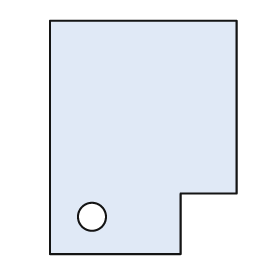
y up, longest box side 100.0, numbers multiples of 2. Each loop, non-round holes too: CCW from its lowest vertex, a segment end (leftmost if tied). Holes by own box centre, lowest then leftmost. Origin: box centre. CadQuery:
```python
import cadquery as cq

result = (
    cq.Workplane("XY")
    .moveTo(-40.0, -50.0)
    .lineTo(16.0, -50.0)
    .lineTo(16.0, -24.0)
    .lineTo(40.0, -24.0)
    .lineTo(40.0, 50.0)
    .lineTo(-40.0, 50.0)
    .close()
    .moveTo(-22.0, -34.0)
    .circle(6.0)
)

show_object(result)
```